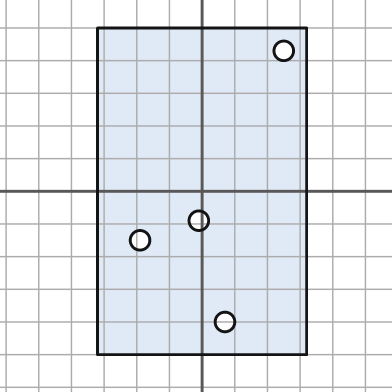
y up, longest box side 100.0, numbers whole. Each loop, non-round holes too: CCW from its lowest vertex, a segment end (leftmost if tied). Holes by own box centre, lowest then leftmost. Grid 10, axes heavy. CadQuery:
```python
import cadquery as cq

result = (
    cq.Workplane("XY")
    .moveTo(-32.0, -50.0)
    .lineTo(32.0, -50.0)
    .lineTo(32.0, 50.0)
    .lineTo(-32.0, 50.0)
    .close()
    .moveTo(7.0, -40.0)
    .circle(3.0)
    .moveTo(-19.0, -15.0)
    .circle(3.0)
    .moveTo(-1.0, -9.0)
    .circle(3.0)
    .moveTo(25.0, 43.0)
    .circle(3.0)
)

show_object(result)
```